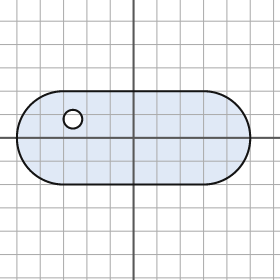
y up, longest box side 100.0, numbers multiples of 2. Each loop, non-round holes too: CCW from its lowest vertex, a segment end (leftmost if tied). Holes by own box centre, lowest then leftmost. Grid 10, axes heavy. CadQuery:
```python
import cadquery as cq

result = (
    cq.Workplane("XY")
    .moveTo(-30.0, -20.0)
    .lineTo(30.0, -20.0)
    .threePointArc((50.0, 0.0), (30.0, 20.0))
    .lineTo(-30.0, 20.0)
    .threePointArc((-50.0, 0.0), (-30.0, -20.0))
    .close()
    .moveTo(-26.0, 8.0)
    .circle(4.0)
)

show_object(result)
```